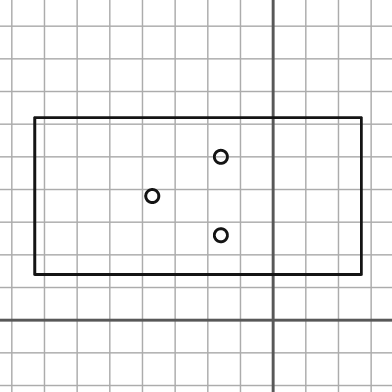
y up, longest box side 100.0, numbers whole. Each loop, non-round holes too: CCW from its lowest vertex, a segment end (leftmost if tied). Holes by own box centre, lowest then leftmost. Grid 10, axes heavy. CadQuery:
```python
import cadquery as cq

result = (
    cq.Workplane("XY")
    .moveTo(-73.0, 14.0)
    .lineTo(27.0, 14.0)
    .lineTo(27.0, 62.0)
    .lineTo(-73.0, 62.0)
    .close()
    .moveTo(-16.0, 26.0)
    .circle(2.0)
    .moveTo(-37.0, 38.0)
    .circle(2.0)
    .moveTo(-16.0, 50.0)
    .circle(2.0)
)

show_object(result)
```